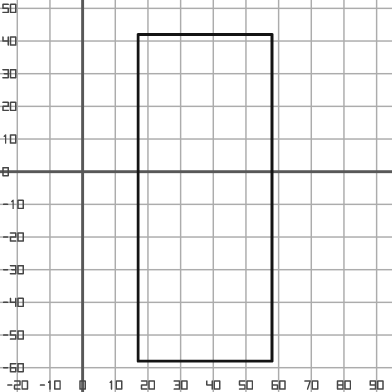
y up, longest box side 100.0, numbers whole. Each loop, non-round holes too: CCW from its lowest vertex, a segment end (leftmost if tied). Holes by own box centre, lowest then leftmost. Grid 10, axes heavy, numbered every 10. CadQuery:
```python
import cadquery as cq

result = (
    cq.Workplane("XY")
    .moveTo(17.0, -58.0)
    .lineTo(58.0, -58.0)
    .lineTo(58.0, 42.0)
    .lineTo(17.0, 42.0)
    .close()
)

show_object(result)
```